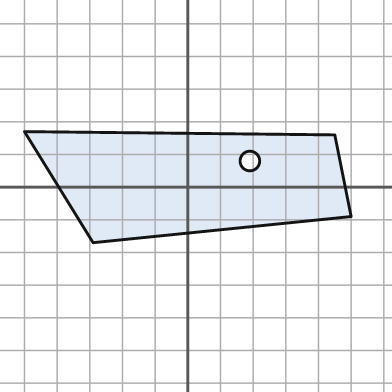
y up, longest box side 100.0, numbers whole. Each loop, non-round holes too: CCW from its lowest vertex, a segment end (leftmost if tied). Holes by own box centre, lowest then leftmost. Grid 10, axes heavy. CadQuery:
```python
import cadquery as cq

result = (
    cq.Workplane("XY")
    .moveTo(-29.0, -17.0)
    .lineTo(50.0, -9.0)
    .lineTo(45.0, 16.0)
    .lineTo(-50.0, 17.0)
    .close()
    .moveTo(19.0, 8.0)
    .circle(3.0)
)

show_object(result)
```